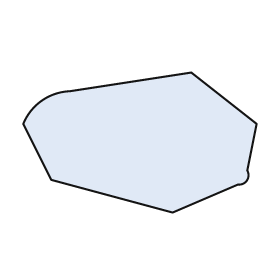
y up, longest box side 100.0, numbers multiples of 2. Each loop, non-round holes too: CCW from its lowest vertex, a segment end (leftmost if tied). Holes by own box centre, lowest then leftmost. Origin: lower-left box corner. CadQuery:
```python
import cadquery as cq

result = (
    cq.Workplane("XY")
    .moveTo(64.0, 0.0)
    .lineTo(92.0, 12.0)
    .threePointArc((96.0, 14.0), (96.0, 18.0))
    .lineTo(100.0, 38.0)
    .lineTo(72.0, 60.0)
    .lineTo(20.0, 52.0)
    .threePointArc((8.0, 48.0), (0.0, 38.0))
    .lineTo(12.0, 14.0)
    .close()
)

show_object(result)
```